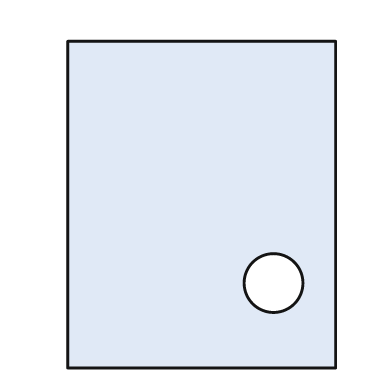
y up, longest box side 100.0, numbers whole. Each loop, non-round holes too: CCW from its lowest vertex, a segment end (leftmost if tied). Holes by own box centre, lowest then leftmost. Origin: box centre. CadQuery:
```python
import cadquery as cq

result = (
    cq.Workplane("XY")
    .moveTo(-41.0, -50.0)
    .lineTo(41.0, -50.0)
    .lineTo(41.0, 50.0)
    .lineTo(-41.0, 50.0)
    .close()
    .moveTo(22.0, -24.0)
    .circle(9.0)
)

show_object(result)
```